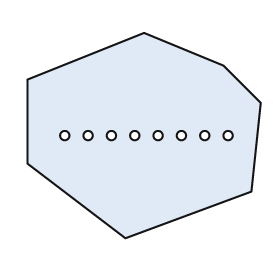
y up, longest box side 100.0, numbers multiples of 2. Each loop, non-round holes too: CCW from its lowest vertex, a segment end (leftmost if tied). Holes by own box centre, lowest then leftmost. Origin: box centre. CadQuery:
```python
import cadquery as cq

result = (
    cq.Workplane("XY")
    .moveTo(-8.0, -44.0)
    .lineTo(46.0, -24.0)
    .lineTo(50.0, 14.0)
    .lineTo(34.0, 30.0)
    .lineTo(0.0, 44.0)
    .lineTo(-50.0, 24.0)
    .lineTo(-50.0, -12.0)
    .close()
    .moveTo(-34.0, 0.0)
    .circle(2.0)
    .moveTo(-24.0, 0.0)
    .circle(2.0)
    .moveTo(-14.0, 0.0)
    .circle(2.0)
    .moveTo(-4.0, 0.0)
    .circle(2.0)
    .moveTo(6.0, 0.0)
    .circle(2.0)
    .moveTo(16.0, 0.0)
    .circle(2.0)
    .moveTo(26.0, 0.0)
    .circle(2.0)
    .moveTo(36.0, 0.0)
    .circle(2.0)
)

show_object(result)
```